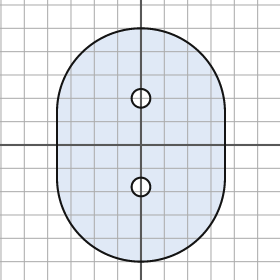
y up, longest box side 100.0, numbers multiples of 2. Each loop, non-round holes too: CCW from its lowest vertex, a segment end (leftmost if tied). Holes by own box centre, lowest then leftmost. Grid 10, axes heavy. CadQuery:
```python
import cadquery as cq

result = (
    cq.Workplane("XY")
    .moveTo(-36.0, -14.0)
    .threePointArc((0.0, -50.0), (36.0, -14.0))
    .lineTo(36.0, 14.0)
    .threePointArc((0.0, 50.0), (-36.0, 14.0))
    .close()
    .moveTo(0.0, -18.0)
    .circle(4.0)
    .moveTo(0.0, 20.0)
    .circle(4.0)
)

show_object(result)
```